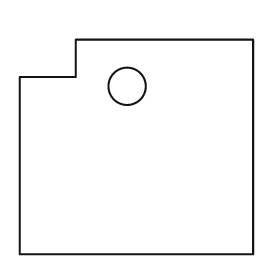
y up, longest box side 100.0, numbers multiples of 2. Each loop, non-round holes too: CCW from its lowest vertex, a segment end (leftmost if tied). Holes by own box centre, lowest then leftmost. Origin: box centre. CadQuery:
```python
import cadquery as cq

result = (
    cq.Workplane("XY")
    .moveTo(-50.0, -46.0)
    .lineTo(50.0, -46.0)
    .lineTo(50.0, 46.0)
    .lineTo(-26.0, 46.0)
    .lineTo(-26.0, 30.0)
    .lineTo(-50.0, 30.0)
    .close()
    .moveTo(-4.0, 26.0)
    .circle(8.0)
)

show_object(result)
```